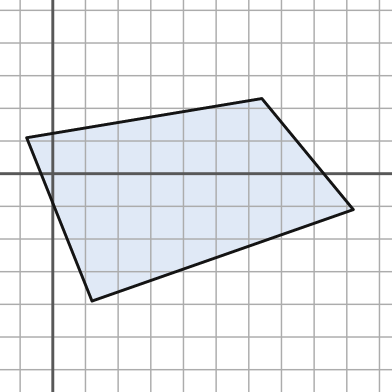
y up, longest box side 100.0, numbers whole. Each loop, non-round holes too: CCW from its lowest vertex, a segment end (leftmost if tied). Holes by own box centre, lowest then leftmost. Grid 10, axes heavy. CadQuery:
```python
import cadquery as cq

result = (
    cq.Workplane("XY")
    .moveTo(12.0, -39.0)
    .lineTo(92.0, -11.0)
    .lineTo(64.0, 23.0)
    .lineTo(-8.0, 11.0)
    .close()
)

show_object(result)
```